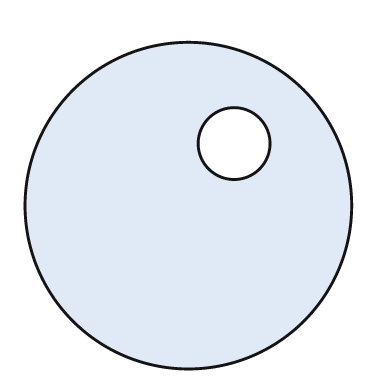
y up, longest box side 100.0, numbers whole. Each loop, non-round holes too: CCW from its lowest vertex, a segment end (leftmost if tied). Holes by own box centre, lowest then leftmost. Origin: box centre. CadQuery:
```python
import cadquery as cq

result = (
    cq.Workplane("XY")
    .moveTo(0.0, 0.0)
    .circle(50.0)
    .moveTo(14.0, 19.0)
    .circle(11.0)
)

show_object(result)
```